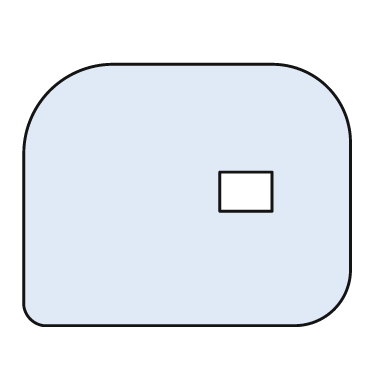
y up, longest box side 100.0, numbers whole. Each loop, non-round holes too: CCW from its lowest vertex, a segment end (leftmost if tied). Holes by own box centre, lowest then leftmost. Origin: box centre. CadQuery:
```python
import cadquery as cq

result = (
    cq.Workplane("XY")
    .moveTo(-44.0, -40.0)
    .lineTo(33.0, -40.0)
    .threePointArc((45.0, -35.0), (50.0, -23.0))
    .lineTo(50.0, 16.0)
    .threePointArc((43.0, 33.0), (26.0, 40.0))
    .lineTo(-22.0, 40.0)
    .threePointArc((-42.0, 32.0), (-50.0, 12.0))
    .lineTo(-50.0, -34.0)
    .threePointArc((-48.0, -38.0), (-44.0, -40.0))
    .close()
    .moveTo(10.0, -5.0)
    .lineTo(26.0, -5.0)
    .lineTo(26.0, 7.0)
    .lineTo(10.0, 7.0)
    .close()
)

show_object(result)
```